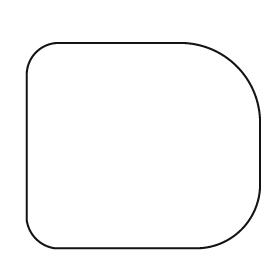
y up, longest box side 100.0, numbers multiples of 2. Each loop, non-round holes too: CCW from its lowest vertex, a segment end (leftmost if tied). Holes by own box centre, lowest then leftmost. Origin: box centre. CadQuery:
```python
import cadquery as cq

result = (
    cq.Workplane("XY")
    .moveTo(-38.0, -44.0)
    .lineTo(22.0, -44.0)
    .threePointArc((42.0, -36.0), (50.0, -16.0))
    .lineTo(50.0, 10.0)
    .threePointArc((40.0, 34.0), (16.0, 44.0))
    .lineTo(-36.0, 44.0)
    .threePointArc((-46.0, 40.0), (-50.0, 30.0))
    .lineTo(-50.0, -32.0)
    .threePointArc((-46.0, -40.0), (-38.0, -44.0))
    .close()
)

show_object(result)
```